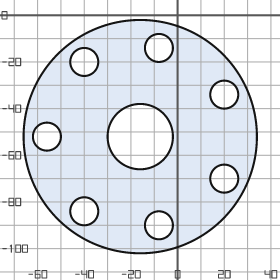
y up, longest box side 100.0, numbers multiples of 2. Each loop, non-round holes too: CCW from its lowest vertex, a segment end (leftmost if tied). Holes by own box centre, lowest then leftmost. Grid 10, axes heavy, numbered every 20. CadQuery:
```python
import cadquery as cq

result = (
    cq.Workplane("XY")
    .moveTo(-16.0, -52.0)
    .circle(50.0)
    .moveTo(-8.0, -90.0)
    .circle(6.0)
    .moveTo(-40.0, -84.0)
    .circle(6.0)
    .moveTo(20.0, -70.0)
    .circle(6.0)
    .moveTo(-56.0, -52.0)
    .circle(6.0)
    .moveTo(-16.0, -52.0)
    .circle(14.0)
    .moveTo(20.0, -34.0)
    .circle(6.0)
    .moveTo(-40.0, -20.0)
    .circle(6.0)
    .moveTo(-8.0, -14.0)
    .circle(6.0)
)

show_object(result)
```